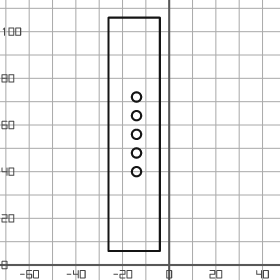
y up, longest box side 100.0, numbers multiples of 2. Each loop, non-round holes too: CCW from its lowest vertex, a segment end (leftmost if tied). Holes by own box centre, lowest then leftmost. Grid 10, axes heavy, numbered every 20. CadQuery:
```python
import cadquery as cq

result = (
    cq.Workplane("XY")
    .moveTo(-26.0, 6.0)
    .lineTo(-4.0, 6.0)
    .lineTo(-4.0, 106.0)
    .lineTo(-26.0, 106.0)
    .close()
    .moveTo(-14.0, 40.0)
    .circle(2.0)
    .moveTo(-14.0, 48.0)
    .circle(2.0)
    .moveTo(-14.0, 56.0)
    .circle(2.0)
    .moveTo(-14.0, 64.0)
    .circle(2.0)
    .moveTo(-14.0, 72.0)
    .circle(2.0)
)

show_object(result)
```